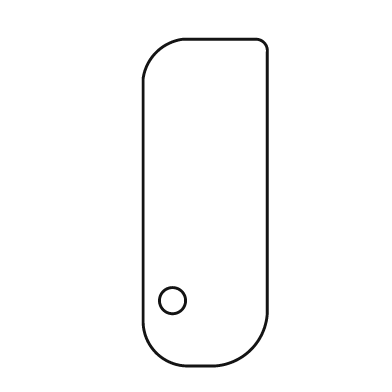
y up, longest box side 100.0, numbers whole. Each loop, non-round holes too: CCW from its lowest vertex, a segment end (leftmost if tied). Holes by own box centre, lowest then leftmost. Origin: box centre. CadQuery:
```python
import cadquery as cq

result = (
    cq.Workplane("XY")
    .moveTo(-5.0, -50.0)
    .lineTo(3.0, -50.0)
    .threePointArc((14.0, -45.0), (19.0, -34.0))
    .lineTo(19.0, 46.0)
    .threePointArc((18.0, 49.0), (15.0, 50.0))
    .lineTo(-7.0, 50.0)
    .threePointArc((-15.0, 46.0), (-19.0, 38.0))
    .lineTo(-19.0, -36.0)
    .threePointArc((-15.0, -46.0), (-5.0, -50.0))
    .close()
    .moveTo(-10.0, -30.0)
    .circle(4.0)
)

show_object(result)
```